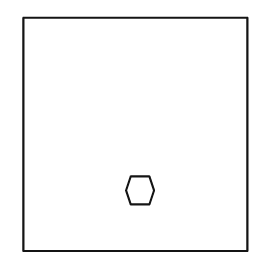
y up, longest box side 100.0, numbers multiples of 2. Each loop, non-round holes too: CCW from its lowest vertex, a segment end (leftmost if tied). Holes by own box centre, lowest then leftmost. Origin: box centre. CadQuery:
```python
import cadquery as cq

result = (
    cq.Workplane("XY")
    .moveTo(-48.0, -50.0)
    .lineTo(48.0, -50.0)
    .lineTo(48.0, 50.0)
    .lineTo(-48.0, 50.0)
    .close()
    .moveTo(-2.0, -30.0)
    .lineTo(6.0, -30.0)
    .lineTo(8.0, -24.0)
    .lineTo(6.0, -18.0)
    .lineTo(-2.0, -18.0)
    .lineTo(-4.0, -24.0)
    .close()
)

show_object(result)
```